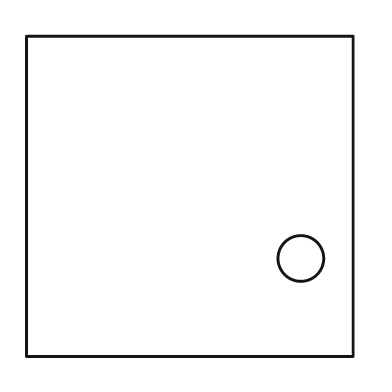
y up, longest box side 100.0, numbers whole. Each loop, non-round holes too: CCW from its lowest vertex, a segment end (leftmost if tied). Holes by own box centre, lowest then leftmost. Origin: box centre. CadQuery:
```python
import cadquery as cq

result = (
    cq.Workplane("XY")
    .moveTo(-50.0, -49.0)
    .lineTo(50.0, -49.0)
    .lineTo(50.0, 49.0)
    .lineTo(-50.0, 49.0)
    .close()
    .moveTo(34.0, -19.0)
    .circle(7.0)
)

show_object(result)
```